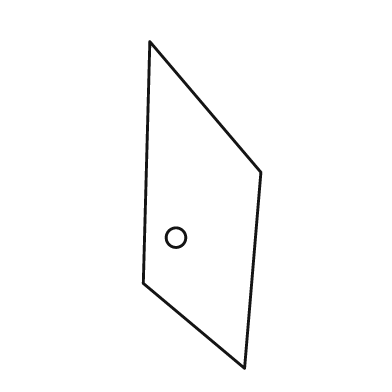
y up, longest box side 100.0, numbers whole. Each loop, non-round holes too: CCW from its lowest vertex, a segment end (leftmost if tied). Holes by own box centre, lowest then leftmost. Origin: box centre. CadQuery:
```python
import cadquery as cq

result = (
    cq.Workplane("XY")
    .moveTo(13.0, -50.0)
    .lineTo(18.0, 10.0)
    .lineTo(-16.0, 50.0)
    .lineTo(-18.0, -24.0)
    .close()
    .moveTo(-8.0, -10.0)
    .circle(3.0)
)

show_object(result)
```